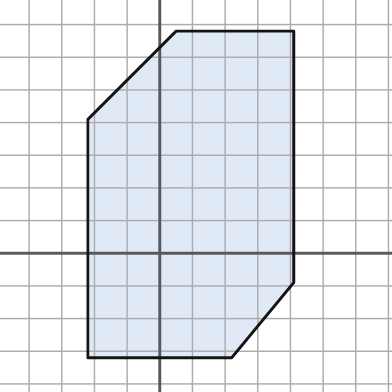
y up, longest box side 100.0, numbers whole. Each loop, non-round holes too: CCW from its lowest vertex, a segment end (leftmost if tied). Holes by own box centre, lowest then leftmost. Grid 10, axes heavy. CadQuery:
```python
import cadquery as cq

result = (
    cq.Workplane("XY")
    .moveTo(-22.0, -32.0)
    .lineTo(22.0, -32.0)
    .lineTo(41.0, -9.0)
    .lineTo(41.0, 68.0)
    .lineTo(5.0, 68.0)
    .lineTo(-22.0, 41.0)
    .close()
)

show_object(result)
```